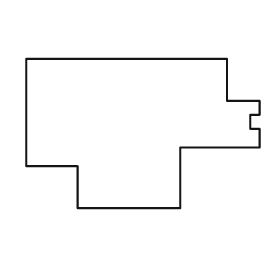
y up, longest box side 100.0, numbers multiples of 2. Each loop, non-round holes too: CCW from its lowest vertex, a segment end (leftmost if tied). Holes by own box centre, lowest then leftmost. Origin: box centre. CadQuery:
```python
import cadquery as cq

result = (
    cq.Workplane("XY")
    .moveTo(-28.0, -32.0)
    .lineTo(16.0, -32.0)
    .lineTo(16.0, -6.0)
    .lineTo(50.0, -6.0)
    .lineTo(50.0, 2.0)
    .lineTo(46.0, 2.0)
    .lineTo(46.0, 8.0)
    .lineTo(50.0, 8.0)
    .lineTo(50.0, 14.0)
    .lineTo(36.0, 14.0)
    .lineTo(36.0, 32.0)
    .lineTo(-50.0, 32.0)
    .lineTo(-50.0, -14.0)
    .lineTo(-28.0, -14.0)
    .close()
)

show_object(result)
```